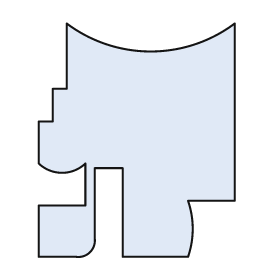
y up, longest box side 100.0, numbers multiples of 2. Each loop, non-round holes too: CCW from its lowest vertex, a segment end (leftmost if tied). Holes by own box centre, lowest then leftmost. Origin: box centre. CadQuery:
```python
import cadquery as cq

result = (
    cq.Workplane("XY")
    .moveTo(-42.0, -50.0)
    .lineTo(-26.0, -50.0)
    .threePointArc((-20.0, -48.0), (-18.0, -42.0))
    .lineTo(-18.0, -12.0)
    .lineTo(-6.0, -12.0)
    .lineTo(-6.0, -50.0)
    .lineTo(22.0, -50.0)
    .threePointArc((24.0, -38.0), (22.0, -26.0))
    .lineTo(42.0, -26.0)
    .lineTo(42.0, 50.0)
    .threePointArc((6.0, 38.0), (-30.0, 50.0))
    .lineTo(-30.0, 22.0)
    .lineTo(-36.0, 22.0)
    .lineTo(-36.0, 8.0)
    .lineTo(-42.0, 8.0)
    .lineTo(-42.0, -10.0)
    .threePointArc((-32.0, -14.0), (-22.0, -10.0))
    .lineTo(-22.0, -28.0)
    .lineTo(-42.0, -28.0)
    .close()
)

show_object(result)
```